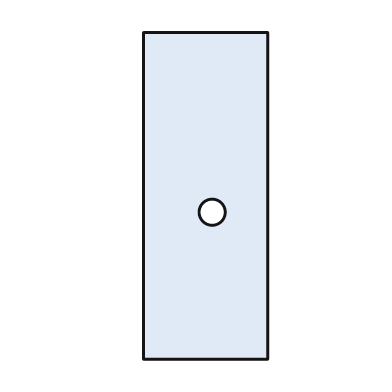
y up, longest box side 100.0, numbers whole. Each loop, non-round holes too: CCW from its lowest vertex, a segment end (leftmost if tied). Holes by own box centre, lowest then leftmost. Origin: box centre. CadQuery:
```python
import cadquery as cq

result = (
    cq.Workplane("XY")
    .moveTo(-19.0, -50.0)
    .lineTo(19.0, -50.0)
    .lineTo(19.0, 50.0)
    .lineTo(-19.0, 50.0)
    .close()
    .moveTo(2.0, -5.0)
    .circle(4.0)
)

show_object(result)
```